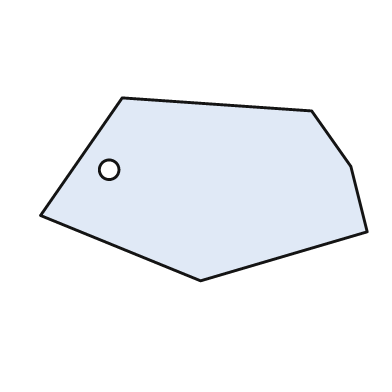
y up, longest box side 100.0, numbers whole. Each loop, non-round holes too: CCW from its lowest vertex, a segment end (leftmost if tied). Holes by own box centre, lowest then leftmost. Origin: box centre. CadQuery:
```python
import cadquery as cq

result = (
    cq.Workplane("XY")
    .moveTo(-1.0, -28.0)
    .lineTo(50.0, -13.0)
    .lineTo(45.0, 7.0)
    .lineTo(33.0, 24.0)
    .lineTo(-25.0, 28.0)
    .lineTo(-50.0, -8.0)
    .close()
    .moveTo(-29.0, 6.0)
    .circle(3.0)
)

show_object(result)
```